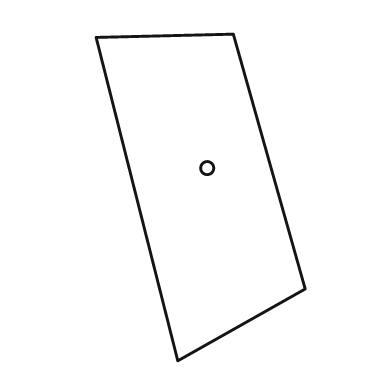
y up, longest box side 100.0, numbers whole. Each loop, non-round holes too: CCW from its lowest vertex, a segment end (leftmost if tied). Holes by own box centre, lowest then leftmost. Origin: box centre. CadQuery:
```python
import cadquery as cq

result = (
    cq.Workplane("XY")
    .moveTo(-7.0, -50.0)
    .lineTo(32.0, -28.0)
    .lineTo(10.0, 50.0)
    .lineTo(-32.0, 49.0)
    .close()
    .moveTo(2.0, 9.0)
    .circle(2.0)
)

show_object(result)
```